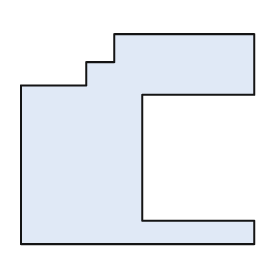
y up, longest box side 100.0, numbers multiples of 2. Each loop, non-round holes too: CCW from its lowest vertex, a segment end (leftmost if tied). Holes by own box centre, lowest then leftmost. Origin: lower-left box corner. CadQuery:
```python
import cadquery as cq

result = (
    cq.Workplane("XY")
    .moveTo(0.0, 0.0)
    .lineTo(100.0, 0.0)
    .lineTo(100.0, 10.0)
    .lineTo(52.0, 10.0)
    .lineTo(52.0, 64.0)
    .lineTo(100.0, 64.0)
    .lineTo(100.0, 90.0)
    .lineTo(40.0, 90.0)
    .lineTo(40.0, 78.0)
    .lineTo(28.0, 78.0)
    .lineTo(28.0, 68.0)
    .lineTo(0.0, 68.0)
    .close()
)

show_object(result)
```